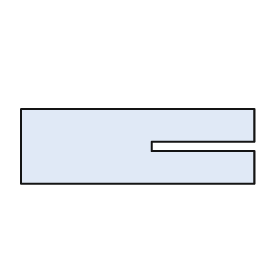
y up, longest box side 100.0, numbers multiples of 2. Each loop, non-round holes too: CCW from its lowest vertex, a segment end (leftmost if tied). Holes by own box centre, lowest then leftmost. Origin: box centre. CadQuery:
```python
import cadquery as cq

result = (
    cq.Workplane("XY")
    .moveTo(-50.0, -16.0)
    .lineTo(50.0, -16.0)
    .lineTo(50.0, -2.0)
    .lineTo(6.0, -2.0)
    .lineTo(6.0, 2.0)
    .lineTo(50.0, 2.0)
    .lineTo(50.0, 16.0)
    .lineTo(-50.0, 16.0)
    .close()
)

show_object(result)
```